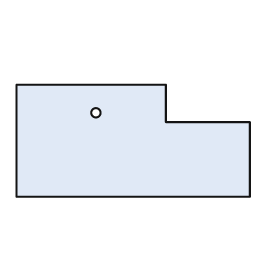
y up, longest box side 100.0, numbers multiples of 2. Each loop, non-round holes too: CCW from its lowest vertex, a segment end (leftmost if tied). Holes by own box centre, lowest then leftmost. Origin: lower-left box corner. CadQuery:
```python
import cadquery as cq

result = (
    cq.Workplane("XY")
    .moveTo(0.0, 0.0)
    .lineTo(100.0, 0.0)
    .lineTo(100.0, 32.0)
    .lineTo(64.0, 32.0)
    .lineTo(64.0, 48.0)
    .lineTo(0.0, 48.0)
    .close()
    .moveTo(34.0, 36.0)
    .circle(2.0)
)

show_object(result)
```